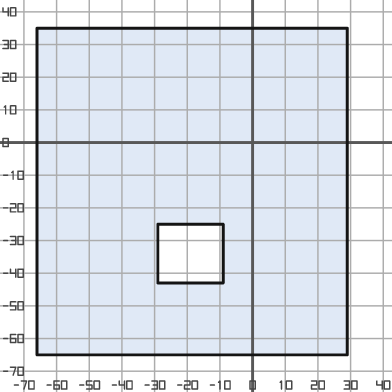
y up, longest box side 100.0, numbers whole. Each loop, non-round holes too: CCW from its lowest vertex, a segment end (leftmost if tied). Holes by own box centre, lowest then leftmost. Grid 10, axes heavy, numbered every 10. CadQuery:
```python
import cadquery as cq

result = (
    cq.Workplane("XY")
    .moveTo(-66.0, -65.0)
    .lineTo(29.0, -65.0)
    .lineTo(29.0, 35.0)
    .lineTo(-66.0, 35.0)
    .close()
    .moveTo(-29.0, -43.0)
    .lineTo(-9.0, -43.0)
    .lineTo(-9.0, -25.0)
    .lineTo(-29.0, -25.0)
    .close()
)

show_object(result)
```